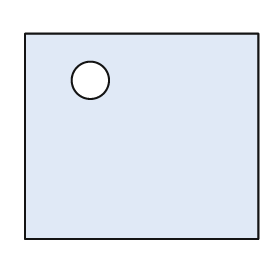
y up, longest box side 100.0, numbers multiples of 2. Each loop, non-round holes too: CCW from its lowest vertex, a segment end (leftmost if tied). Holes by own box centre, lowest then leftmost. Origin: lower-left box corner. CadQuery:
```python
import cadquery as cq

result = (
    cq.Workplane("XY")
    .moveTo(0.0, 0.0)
    .lineTo(100.0, 0.0)
    .lineTo(100.0, 88.0)
    .lineTo(0.0, 88.0)
    .close()
    .moveTo(28.0, 68.0)
    .circle(8.0)
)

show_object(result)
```